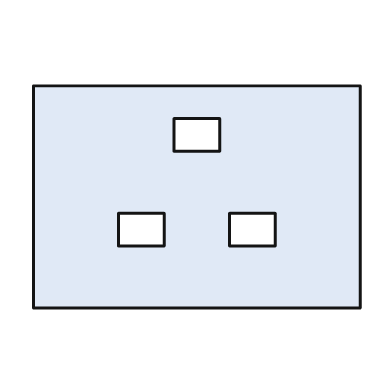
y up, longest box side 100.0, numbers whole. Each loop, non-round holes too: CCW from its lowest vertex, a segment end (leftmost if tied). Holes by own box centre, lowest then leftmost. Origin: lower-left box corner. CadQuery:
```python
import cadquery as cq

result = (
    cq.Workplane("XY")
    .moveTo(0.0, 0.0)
    .lineTo(100.0, 0.0)
    .lineTo(100.0, 68.0)
    .lineTo(0.0, 68.0)
    .close()
    .moveTo(26.0, 19.0)
    .lineTo(40.0, 19.0)
    .lineTo(40.0, 29.0)
    .lineTo(26.0, 29.0)
    .close()
    .moveTo(60.0, 19.0)
    .lineTo(74.0, 19.0)
    .lineTo(74.0, 29.0)
    .lineTo(60.0, 29.0)
    .close()
    .moveTo(43.0, 48.0)
    .lineTo(57.0, 48.0)
    .lineTo(57.0, 58.0)
    .lineTo(43.0, 58.0)
    .close()
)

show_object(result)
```